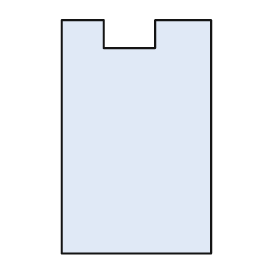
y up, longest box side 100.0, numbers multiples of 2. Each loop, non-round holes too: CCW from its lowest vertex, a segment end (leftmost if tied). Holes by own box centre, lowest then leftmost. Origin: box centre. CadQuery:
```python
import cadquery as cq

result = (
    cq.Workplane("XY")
    .moveTo(-32.0, -50.0)
    .lineTo(32.0, -50.0)
    .lineTo(32.0, 50.0)
    .lineTo(8.0, 50.0)
    .lineTo(8.0, 38.0)
    .lineTo(-14.0, 38.0)
    .lineTo(-14.0, 50.0)
    .lineTo(-32.0, 50.0)
    .close()
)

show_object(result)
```